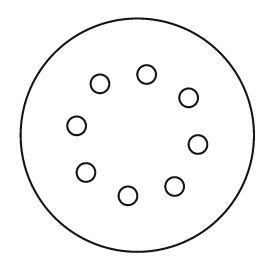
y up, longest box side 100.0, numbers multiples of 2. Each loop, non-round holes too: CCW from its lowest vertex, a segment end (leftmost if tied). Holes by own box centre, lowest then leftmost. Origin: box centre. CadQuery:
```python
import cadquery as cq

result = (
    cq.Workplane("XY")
    .moveTo(0.0, 0.0)
    .circle(50.0)
    .moveTo(-4.0, -26.0)
    .circle(4.0)
    .moveTo(16.0, -22.0)
    .circle(4.0)
    .moveTo(-22.0, -16.0)
    .circle(4.0)
    .moveTo(26.0, -4.0)
    .circle(4.0)
    .moveTo(-26.0, 4.0)
    .circle(4.0)
    .moveTo(22.0, 16.0)
    .circle(4.0)
    .moveTo(-16.0, 22.0)
    .circle(4.0)
    .moveTo(4.0, 26.0)
    .circle(4.0)
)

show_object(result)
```